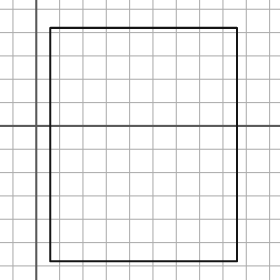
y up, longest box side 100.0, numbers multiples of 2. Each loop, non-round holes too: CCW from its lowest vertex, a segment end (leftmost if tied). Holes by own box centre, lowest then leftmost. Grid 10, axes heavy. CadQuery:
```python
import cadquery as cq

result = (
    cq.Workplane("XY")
    .moveTo(6.0, -58.0)
    .lineTo(86.0, -58.0)
    .lineTo(86.0, 42.0)
    .lineTo(6.0, 42.0)
    .close()
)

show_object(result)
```